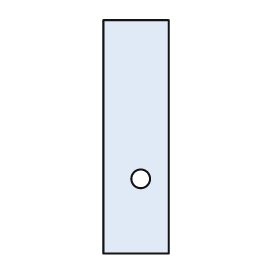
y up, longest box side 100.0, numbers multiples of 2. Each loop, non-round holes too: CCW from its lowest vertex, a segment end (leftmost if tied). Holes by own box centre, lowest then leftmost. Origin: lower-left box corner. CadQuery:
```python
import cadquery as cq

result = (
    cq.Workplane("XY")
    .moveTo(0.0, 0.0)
    .lineTo(28.0, 0.0)
    .lineTo(28.0, 100.0)
    .lineTo(0.0, 100.0)
    .close()
    .moveTo(16.0, 32.0)
    .circle(4.0)
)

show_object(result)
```